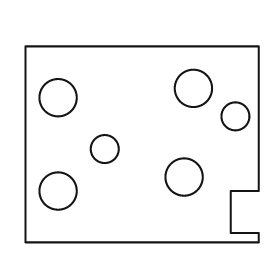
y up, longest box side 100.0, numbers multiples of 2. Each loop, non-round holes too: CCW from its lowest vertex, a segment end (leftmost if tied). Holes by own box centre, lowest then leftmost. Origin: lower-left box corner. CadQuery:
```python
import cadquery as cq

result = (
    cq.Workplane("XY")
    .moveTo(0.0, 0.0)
    .lineTo(100.0, 0.0)
    .lineTo(100.0, 4.0)
    .lineTo(88.0, 4.0)
    .lineTo(88.0, 22.0)
    .lineTo(100.0, 22.0)
    .lineTo(100.0, 84.0)
    .lineTo(0.0, 84.0)
    .close()
    .moveTo(14.0, 22.0)
    .circle(8.0)
    .moveTo(68.0, 28.0)
    .circle(8.0)
    .moveTo(34.0, 40.0)
    .circle(6.0)
    .moveTo(90.0, 54.0)
    .circle(6.0)
    .moveTo(14.0, 62.0)
    .circle(8.0)
    .moveTo(72.0, 66.0)
    .circle(8.0)
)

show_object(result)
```